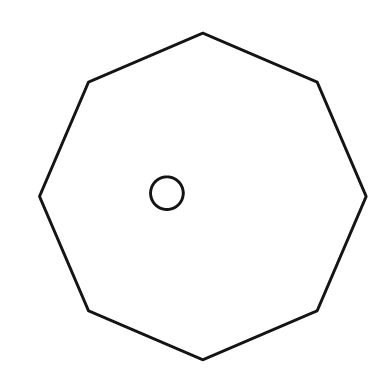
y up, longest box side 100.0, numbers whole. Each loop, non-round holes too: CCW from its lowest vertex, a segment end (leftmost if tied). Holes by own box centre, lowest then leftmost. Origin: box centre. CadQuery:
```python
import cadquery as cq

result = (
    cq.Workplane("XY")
    .moveTo(0.0, -50.0)
    .lineTo(35.0, -35.0)
    .lineTo(50.0, 0.0)
    .lineTo(35.0, 35.0)
    .lineTo(0.0, 50.0)
    .lineTo(-35.0, 35.0)
    .lineTo(-50.0, 0.0)
    .lineTo(-35.0, -35.0)
    .close()
    .moveTo(-11.0, 1.0)
    .circle(5.0)
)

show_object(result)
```